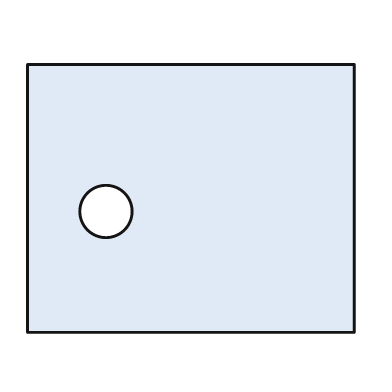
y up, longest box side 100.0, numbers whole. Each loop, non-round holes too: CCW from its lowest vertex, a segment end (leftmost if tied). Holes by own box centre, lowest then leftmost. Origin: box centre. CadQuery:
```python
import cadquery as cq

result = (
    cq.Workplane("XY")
    .moveTo(-50.0, -41.0)
    .lineTo(50.0, -41.0)
    .lineTo(50.0, 41.0)
    .lineTo(-50.0, 41.0)
    .close()
    .moveTo(-26.0, -4.0)
    .circle(8.0)
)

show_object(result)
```